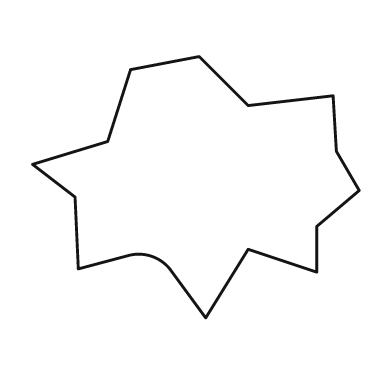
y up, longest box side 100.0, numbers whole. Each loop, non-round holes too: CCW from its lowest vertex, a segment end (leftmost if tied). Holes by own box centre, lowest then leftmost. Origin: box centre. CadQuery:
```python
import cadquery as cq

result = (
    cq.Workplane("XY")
    .moveTo(3.0, -40.0)
    .lineTo(16.0, -19.0)
    .lineTo(37.0, -26.0)
    .lineTo(37.0, -12.0)
    .lineTo(50.0, -1.0)
    .lineTo(43.0, 11.0)
    .lineTo(42.0, 28.0)
    .lineTo(16.0, 25.0)
    .lineTo(1.0, 40.0)
    .lineTo(-20.0, 36.0)
    .lineTo(-27.0, 14.0)
    .lineTo(-50.0, 7.0)
    .lineTo(-37.0, -3.0)
    .lineTo(-36.0, -25.0)
    .lineTo(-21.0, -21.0)
    .threePointArc((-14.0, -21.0), (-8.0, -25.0))
    .close()
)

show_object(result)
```